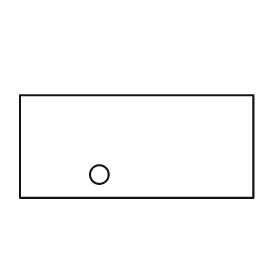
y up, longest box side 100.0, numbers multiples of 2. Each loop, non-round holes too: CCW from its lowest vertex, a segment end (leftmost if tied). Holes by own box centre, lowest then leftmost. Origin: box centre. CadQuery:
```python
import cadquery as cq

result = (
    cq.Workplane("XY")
    .moveTo(-50.0, -22.0)
    .lineTo(50.0, -22.0)
    .lineTo(50.0, 22.0)
    .lineTo(-50.0, 22.0)
    .close()
    .moveTo(-16.0, -12.0)
    .circle(4.0)
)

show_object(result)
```